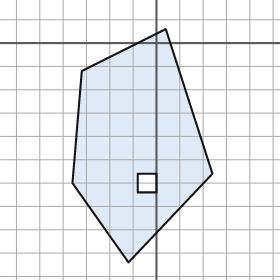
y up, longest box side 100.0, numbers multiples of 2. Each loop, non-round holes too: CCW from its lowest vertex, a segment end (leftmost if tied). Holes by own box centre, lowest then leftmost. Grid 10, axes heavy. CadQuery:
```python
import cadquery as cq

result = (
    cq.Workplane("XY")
    .moveTo(-12.0, -94.0)
    .lineTo(24.0, -56.0)
    .lineTo(4.0, 6.0)
    .lineTo(-32.0, -12.0)
    .lineTo(-36.0, -60.0)
    .close()
    .moveTo(-8.0, -64.0)
    .lineTo(0.0, -64.0)
    .lineTo(0.0, -56.0)
    .lineTo(-8.0, -56.0)
    .close()
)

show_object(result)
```